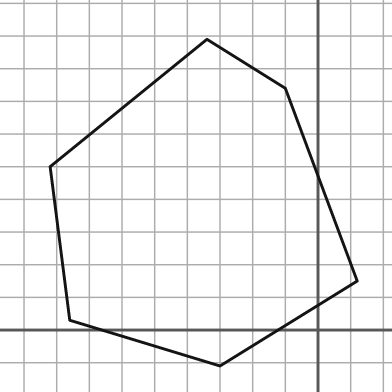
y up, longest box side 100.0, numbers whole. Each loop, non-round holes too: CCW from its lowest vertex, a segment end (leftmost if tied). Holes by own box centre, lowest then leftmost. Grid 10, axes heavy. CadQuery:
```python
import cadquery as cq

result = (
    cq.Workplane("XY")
    .moveTo(-30.0, -11.0)
    .lineTo(12.0, 15.0)
    .lineTo(-10.0, 74.0)
    .lineTo(-34.0, 89.0)
    .lineTo(-82.0, 50.0)
    .lineTo(-76.0, 3.0)
    .close()
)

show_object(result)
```